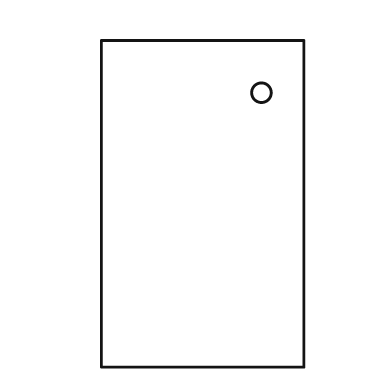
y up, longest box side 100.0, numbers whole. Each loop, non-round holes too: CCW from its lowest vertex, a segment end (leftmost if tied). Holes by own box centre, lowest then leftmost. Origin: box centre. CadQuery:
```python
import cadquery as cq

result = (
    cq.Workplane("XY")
    .moveTo(-31.0, -50.0)
    .lineTo(31.0, -50.0)
    .lineTo(31.0, 50.0)
    .lineTo(-31.0, 50.0)
    .close()
    .moveTo(18.0, 34.0)
    .circle(3.0)
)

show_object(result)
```